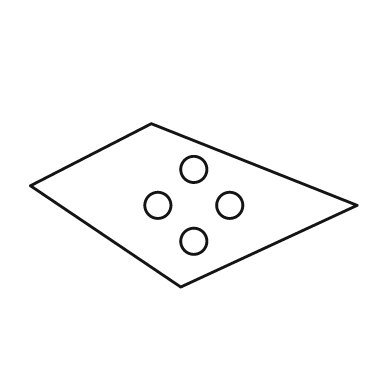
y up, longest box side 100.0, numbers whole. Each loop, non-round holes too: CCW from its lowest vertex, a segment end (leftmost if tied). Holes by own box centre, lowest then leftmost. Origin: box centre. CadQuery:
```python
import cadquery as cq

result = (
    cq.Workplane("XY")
    .moveTo(-4.0, -25.0)
    .lineTo(50.0, 0.0)
    .lineTo(-13.0, 25.0)
    .lineTo(-50.0, 6.0)
    .close()
    .moveTo(0.0, -11.0)
    .circle(4.0)
    .moveTo(-11.0, 0.0)
    .circle(4.0)
    .moveTo(11.0, 0.0)
    .circle(4.0)
    .moveTo(0.0, 11.0)
    .circle(4.0)
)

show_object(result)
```